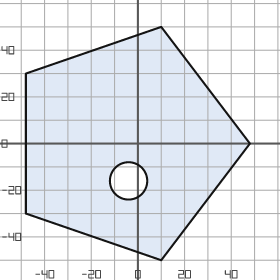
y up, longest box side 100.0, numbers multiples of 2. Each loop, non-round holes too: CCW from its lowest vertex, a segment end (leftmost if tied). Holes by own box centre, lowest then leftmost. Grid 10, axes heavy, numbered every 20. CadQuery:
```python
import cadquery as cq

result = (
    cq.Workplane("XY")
    .moveTo(10.0, -50.0)
    .lineTo(48.0, 0.0)
    .lineTo(10.0, 50.0)
    .lineTo(-48.0, 30.0)
    .lineTo(-48.0, -30.0)
    .close()
    .moveTo(-4.0, -16.0)
    .circle(8.0)
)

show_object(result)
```